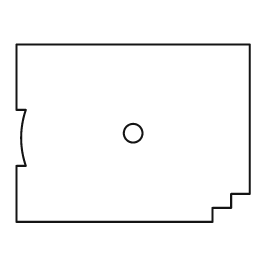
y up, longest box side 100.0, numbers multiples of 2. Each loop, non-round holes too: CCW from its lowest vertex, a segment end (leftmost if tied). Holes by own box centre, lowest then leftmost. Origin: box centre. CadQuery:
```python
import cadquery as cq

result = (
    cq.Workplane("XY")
    .moveTo(-50.0, -38.0)
    .lineTo(34.0, -38.0)
    .lineTo(34.0, -32.0)
    .lineTo(42.0, -32.0)
    .lineTo(42.0, -26.0)
    .lineTo(50.0, -26.0)
    .lineTo(50.0, 38.0)
    .lineTo(-50.0, 38.0)
    .lineTo(-50.0, 10.0)
    .lineTo(-46.0, 10.0)
    .threePointArc((-48.0, -2.0), (-46.0, -14.0))
    .lineTo(-50.0, -14.0)
    .close()
    .moveTo(0.0, 0.0)
    .circle(4.0)
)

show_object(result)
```